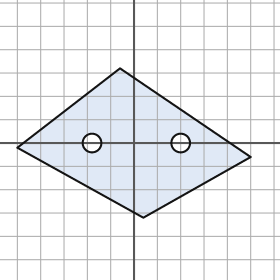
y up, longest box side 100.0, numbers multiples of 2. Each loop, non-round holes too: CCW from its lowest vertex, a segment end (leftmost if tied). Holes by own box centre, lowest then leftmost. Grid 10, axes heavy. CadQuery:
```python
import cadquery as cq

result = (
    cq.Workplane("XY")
    .moveTo(4.0, -32.0)
    .lineTo(50.0, -6.0)
    .lineTo(-6.0, 32.0)
    .lineTo(-50.0, -2.0)
    .close()
    .moveTo(-18.0, 0.0)
    .circle(4.0)
    .moveTo(20.0, 0.0)
    .circle(4.0)
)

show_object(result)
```